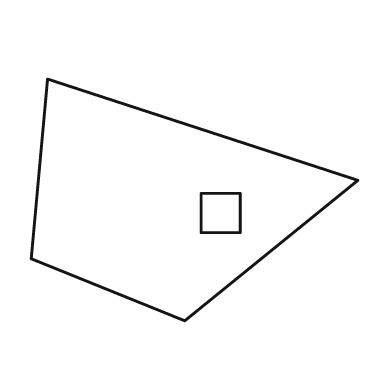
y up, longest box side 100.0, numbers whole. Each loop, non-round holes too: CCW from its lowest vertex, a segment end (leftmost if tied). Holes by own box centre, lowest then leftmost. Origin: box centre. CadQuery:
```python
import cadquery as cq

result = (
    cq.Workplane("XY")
    .moveTo(-3.0, -37.0)
    .lineTo(50.0, 6.0)
    .lineTo(-45.0, 37.0)
    .lineTo(-50.0, -18.0)
    .close()
    .moveTo(2.0, -10.0)
    .lineTo(14.0, -10.0)
    .lineTo(14.0, 2.0)
    .lineTo(2.0, 2.0)
    .close()
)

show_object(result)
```